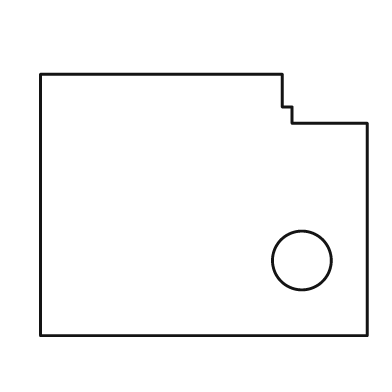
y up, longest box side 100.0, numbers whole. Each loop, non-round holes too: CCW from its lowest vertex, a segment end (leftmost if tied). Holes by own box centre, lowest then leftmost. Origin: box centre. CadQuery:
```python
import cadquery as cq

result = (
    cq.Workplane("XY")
    .moveTo(-50.0, -40.0)
    .lineTo(50.0, -40.0)
    .lineTo(50.0, 25.0)
    .lineTo(27.0, 25.0)
    .lineTo(27.0, 30.0)
    .lineTo(24.0, 30.0)
    .lineTo(24.0, 40.0)
    .lineTo(-50.0, 40.0)
    .close()
    .moveTo(30.0, -17.0)
    .circle(9.0)
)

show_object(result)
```